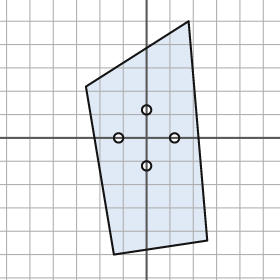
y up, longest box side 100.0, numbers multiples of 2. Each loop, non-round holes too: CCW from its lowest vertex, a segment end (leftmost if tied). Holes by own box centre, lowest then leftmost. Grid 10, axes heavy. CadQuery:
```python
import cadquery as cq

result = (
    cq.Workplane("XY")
    .moveTo(-14.0, -50.0)
    .lineTo(26.0, -44.0)
    .lineTo(18.0, 50.0)
    .lineTo(-26.0, 22.0)
    .close()
    .moveTo(0.0, -12.0)
    .circle(2.0)
    .moveTo(-12.0, 0.0)
    .circle(2.0)
    .moveTo(12.0, 0.0)
    .circle(2.0)
    .moveTo(0.0, 12.0)
    .circle(2.0)
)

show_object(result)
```